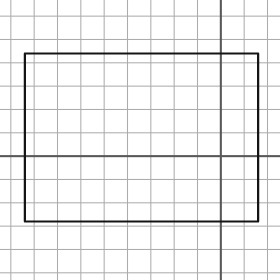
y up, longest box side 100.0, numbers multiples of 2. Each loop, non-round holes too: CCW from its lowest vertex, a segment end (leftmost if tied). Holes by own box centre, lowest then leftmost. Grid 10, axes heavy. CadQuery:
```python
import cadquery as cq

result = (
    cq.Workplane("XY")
    .moveTo(-84.0, -28.0)
    .lineTo(16.0, -28.0)
    .lineTo(16.0, 44.0)
    .lineTo(-84.0, 44.0)
    .close()
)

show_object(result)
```